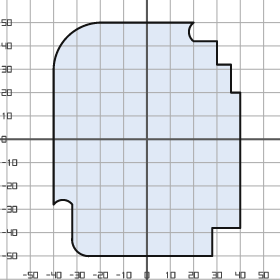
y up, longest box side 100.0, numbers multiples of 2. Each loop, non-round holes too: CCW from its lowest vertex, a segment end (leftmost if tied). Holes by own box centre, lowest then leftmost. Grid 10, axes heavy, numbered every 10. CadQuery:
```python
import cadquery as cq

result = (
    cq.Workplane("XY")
    .moveTo(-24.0, -50.0)
    .lineTo(28.0, -50.0)
    .lineTo(28.0, -38.0)
    .lineTo(40.0, -38.0)
    .lineTo(40.0, 20.0)
    .lineTo(36.0, 20.0)
    .lineTo(36.0, 32.0)
    .lineTo(30.0, 32.0)
    .lineTo(30.0, 42.0)
    .lineTo(20.0, 42.0)
    .threePointArc((18.0, 46.0), (20.0, 50.0))
    .lineTo(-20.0, 50.0)
    .threePointArc((-34.0, 44.0), (-40.0, 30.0))
    .lineTo(-40.0, -28.0)
    .threePointArc((-36.0, -26.0), (-32.0, -28.0))
    .lineTo(-32.0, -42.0)
    .threePointArc((-30.0, -48.0), (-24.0, -50.0))
    .close()
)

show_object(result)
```